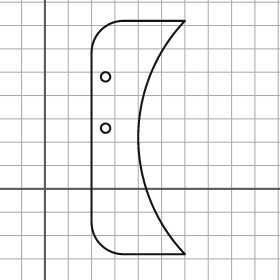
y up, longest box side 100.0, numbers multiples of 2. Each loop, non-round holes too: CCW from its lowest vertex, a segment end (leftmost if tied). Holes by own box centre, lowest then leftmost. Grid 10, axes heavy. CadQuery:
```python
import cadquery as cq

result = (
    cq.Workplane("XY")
    .moveTo(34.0, -28.0)
    .lineTo(60.0, -28.0)
    .threePointArc((40.0, 22.0), (60.0, 72.0))
    .lineTo(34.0, 72.0)
    .threePointArc((24.0, 68.0), (20.0, 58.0))
    .lineTo(20.0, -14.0)
    .threePointArc((24.0, -24.0), (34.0, -28.0))
    .close()
    .moveTo(26.0, 26.0)
    .circle(2.0)
    .moveTo(26.0, 48.0)
    .circle(2.0)
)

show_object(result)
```